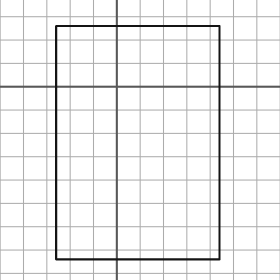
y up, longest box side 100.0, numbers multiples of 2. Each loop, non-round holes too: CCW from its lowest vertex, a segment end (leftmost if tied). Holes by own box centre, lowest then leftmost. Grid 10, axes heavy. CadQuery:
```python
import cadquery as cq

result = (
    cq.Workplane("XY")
    .moveTo(-26.0, -74.0)
    .lineTo(44.0, -74.0)
    .lineTo(44.0, 26.0)
    .lineTo(-26.0, 26.0)
    .close()
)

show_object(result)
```